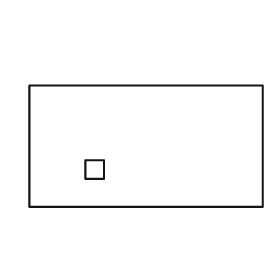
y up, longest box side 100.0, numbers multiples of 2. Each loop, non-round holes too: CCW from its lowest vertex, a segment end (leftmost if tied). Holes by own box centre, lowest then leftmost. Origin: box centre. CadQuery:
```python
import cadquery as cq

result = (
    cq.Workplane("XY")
    .moveTo(-50.0, -26.0)
    .lineTo(50.0, -26.0)
    .lineTo(50.0, 26.0)
    .lineTo(-50.0, 26.0)
    .close()
    .moveTo(-26.0, -14.0)
    .lineTo(-18.0, -14.0)
    .lineTo(-18.0, -6.0)
    .lineTo(-26.0, -6.0)
    .close()
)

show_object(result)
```